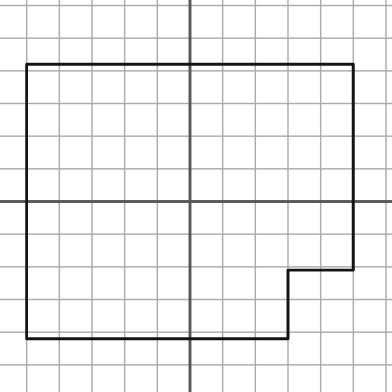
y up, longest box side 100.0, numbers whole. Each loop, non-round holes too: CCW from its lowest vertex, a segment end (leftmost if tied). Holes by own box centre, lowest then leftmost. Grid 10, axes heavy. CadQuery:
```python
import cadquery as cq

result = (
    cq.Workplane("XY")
    .moveTo(-50.0, -42.0)
    .lineTo(30.0, -42.0)
    .lineTo(30.0, -21.0)
    .lineTo(50.0, -21.0)
    .lineTo(50.0, 42.0)
    .lineTo(-50.0, 42.0)
    .close()
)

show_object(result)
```